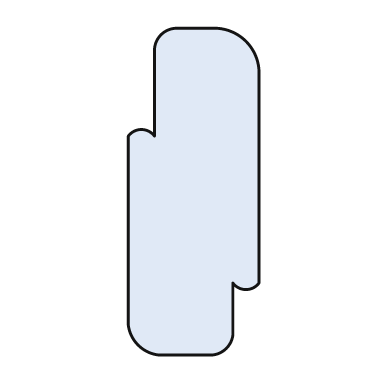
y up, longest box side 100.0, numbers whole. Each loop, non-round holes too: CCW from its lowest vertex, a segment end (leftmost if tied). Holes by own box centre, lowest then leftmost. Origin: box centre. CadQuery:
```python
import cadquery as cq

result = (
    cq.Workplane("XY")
    .moveTo(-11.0, -50.0)
    .lineTo(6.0, -50.0)
    .threePointArc((10.0, -48.0), (12.0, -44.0))
    .lineTo(12.0, -28.0)
    .threePointArc((16.0, -30.0), (20.0, -28.0))
    .lineTo(20.0, 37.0)
    .threePointArc((16.0, 46.0), (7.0, 50.0))
    .lineTo(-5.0, 50.0)
    .threePointArc((-10.0, 48.0), (-12.0, 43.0))
    .lineTo(-12.0, 17.0)
    .threePointArc((-16.0, 19.0), (-20.0, 17.0))
    .lineTo(-20.0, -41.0)
    .threePointArc((-17.0, -47.0), (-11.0, -50.0))
    .close()
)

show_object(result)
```